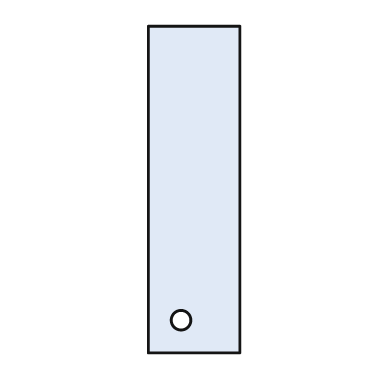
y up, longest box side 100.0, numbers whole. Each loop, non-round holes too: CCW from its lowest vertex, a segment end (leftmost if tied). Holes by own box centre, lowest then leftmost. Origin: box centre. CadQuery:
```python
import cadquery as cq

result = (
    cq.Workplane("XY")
    .moveTo(-14.0, -50.0)
    .lineTo(14.0, -50.0)
    .lineTo(14.0, 50.0)
    .lineTo(-14.0, 50.0)
    .close()
    .moveTo(-4.0, -40.0)
    .circle(3.0)
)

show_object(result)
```